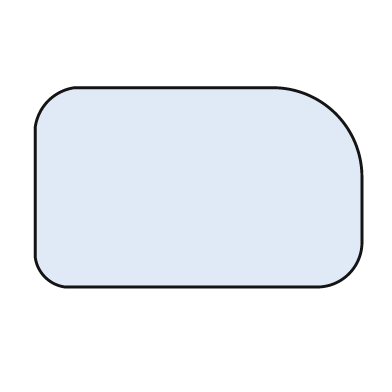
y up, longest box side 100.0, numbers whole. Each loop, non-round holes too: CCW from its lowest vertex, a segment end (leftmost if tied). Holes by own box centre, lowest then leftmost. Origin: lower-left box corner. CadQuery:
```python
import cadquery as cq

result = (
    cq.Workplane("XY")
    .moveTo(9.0, 0.0)
    .lineTo(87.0, 0.0)
    .threePointArc((96.0, 4.0), (100.0, 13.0))
    .lineTo(100.0, 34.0)
    .threePointArc((92.0, 53.0), (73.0, 61.0))
    .lineTo(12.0, 61.0)
    .threePointArc((4.0, 57.0), (0.0, 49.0))
    .lineTo(0.0, 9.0)
    .threePointArc((3.0, 3.0), (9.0, 0.0))
    .close()
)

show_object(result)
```